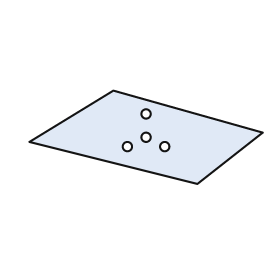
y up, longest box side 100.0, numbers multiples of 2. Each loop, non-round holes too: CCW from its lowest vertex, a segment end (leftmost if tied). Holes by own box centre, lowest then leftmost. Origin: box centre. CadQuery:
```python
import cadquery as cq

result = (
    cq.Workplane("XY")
    .moveTo(22.0, -20.0)
    .lineTo(50.0, 2.0)
    .lineTo(-14.0, 20.0)
    .lineTo(-50.0, -2.0)
    .close()
    .moveTo(-8.0, -4.0)
    .circle(2.0)
    .moveTo(8.0, -4.0)
    .circle(2.0)
    .moveTo(0.0, 0.0)
    .circle(2.0)
    .moveTo(0.0, 10.0)
    .circle(2.0)
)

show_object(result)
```